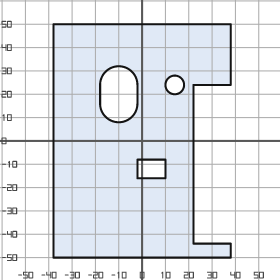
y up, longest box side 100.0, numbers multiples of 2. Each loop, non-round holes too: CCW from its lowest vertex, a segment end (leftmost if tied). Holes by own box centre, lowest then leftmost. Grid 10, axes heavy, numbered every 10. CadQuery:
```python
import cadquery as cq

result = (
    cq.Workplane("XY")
    .moveTo(-38.0, -50.0)
    .lineTo(38.0, -50.0)
    .lineTo(38.0, -44.0)
    .lineTo(22.0, -44.0)
    .lineTo(22.0, 24.0)
    .lineTo(38.0, 24.0)
    .lineTo(38.0, 50.0)
    .lineTo(-38.0, 50.0)
    .close()
    .moveTo(-2.0, -16.0)
    .lineTo(10.0, -16.0)
    .lineTo(10.0, -8.0)
    .lineTo(-2.0, -8.0)
    .close()
    .moveTo(-18.0, 16.0)
    .threePointArc((-10.0, 8.0), (-2.0, 16.0))
    .lineTo(-2.0, 24.0)
    .threePointArc((-10.0, 32.0), (-18.0, 24.0))
    .close()
    .moveTo(14.0, 24.0)
    .circle(4.0)
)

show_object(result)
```